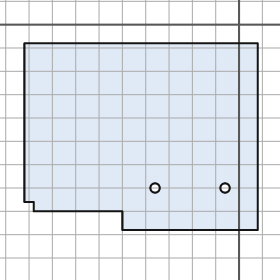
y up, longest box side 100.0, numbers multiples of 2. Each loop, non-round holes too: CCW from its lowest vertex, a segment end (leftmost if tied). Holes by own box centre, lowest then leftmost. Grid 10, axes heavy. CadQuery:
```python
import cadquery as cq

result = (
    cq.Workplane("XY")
    .moveTo(-50.0, -88.0)
    .lineTo(8.0, -88.0)
    .lineTo(8.0, -8.0)
    .lineTo(-92.0, -8.0)
    .lineTo(-92.0, -76.0)
    .lineTo(-88.0, -76.0)
    .lineTo(-88.0, -80.0)
    .lineTo(-50.0, -80.0)
    .close()
    .moveTo(-36.0, -70.0)
    .circle(2.0)
    .moveTo(-6.0, -70.0)
    .circle(2.0)
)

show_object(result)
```